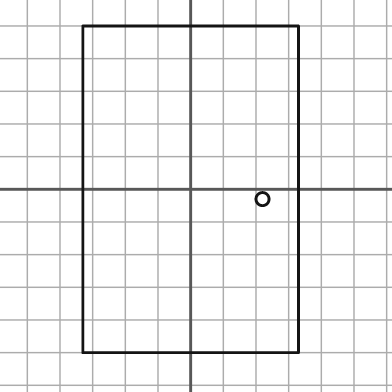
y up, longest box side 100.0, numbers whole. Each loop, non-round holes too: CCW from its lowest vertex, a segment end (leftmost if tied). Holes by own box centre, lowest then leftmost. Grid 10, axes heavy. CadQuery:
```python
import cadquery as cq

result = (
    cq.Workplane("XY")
    .moveTo(-33.0, -50.0)
    .lineTo(33.0, -50.0)
    .lineTo(33.0, 50.0)
    .lineTo(-33.0, 50.0)
    .close()
    .moveTo(22.0, -3.0)
    .circle(2.0)
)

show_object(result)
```